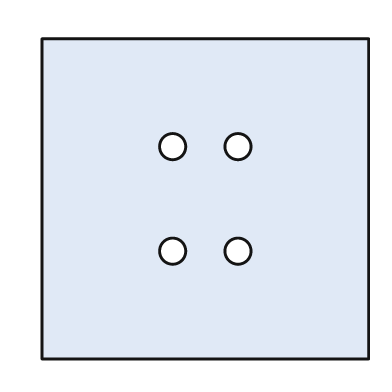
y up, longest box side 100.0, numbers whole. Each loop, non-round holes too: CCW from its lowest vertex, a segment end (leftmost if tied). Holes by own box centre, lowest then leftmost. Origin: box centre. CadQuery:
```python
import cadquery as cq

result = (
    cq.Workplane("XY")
    .moveTo(-50.0, -49.0)
    .lineTo(50.0, -49.0)
    .lineTo(50.0, 49.0)
    .lineTo(-50.0, 49.0)
    .close()
    .moveTo(-10.0, -16.0)
    .circle(4.0)
    .moveTo(10.0, -16.0)
    .circle(4.0)
    .moveTo(-10.0, 16.0)
    .circle(4.0)
    .moveTo(10.0, 16.0)
    .circle(4.0)
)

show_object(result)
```